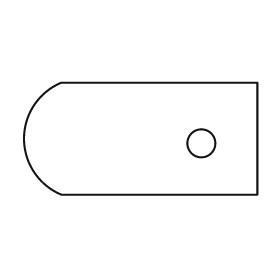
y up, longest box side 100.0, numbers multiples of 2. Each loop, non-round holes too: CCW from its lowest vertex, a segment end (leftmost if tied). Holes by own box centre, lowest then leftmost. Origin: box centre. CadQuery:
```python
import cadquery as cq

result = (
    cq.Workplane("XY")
    .moveTo(-34.0, -24.0)
    .lineTo(50.0, -24.0)
    .lineTo(50.0, 24.0)
    .lineTo(-34.0, 24.0)
    .threePointArc((-50.0, 0.0), (-34.0, -24.0))
    .close()
    .moveTo(26.0, -2.0)
    .circle(6.0)
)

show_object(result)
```